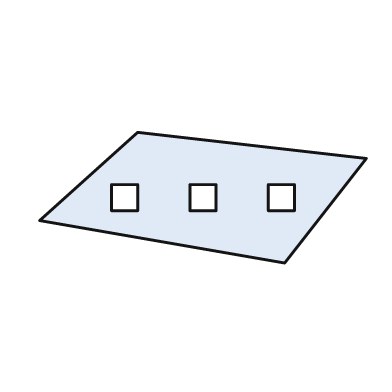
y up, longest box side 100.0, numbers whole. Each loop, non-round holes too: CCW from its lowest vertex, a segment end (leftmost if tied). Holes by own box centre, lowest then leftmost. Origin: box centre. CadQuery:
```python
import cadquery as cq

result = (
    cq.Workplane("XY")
    .moveTo(25.0, -20.0)
    .lineTo(50.0, 12.0)
    .lineTo(-20.0, 20.0)
    .lineTo(-50.0, -7.0)
    .close()
    .moveTo(-28.0, -4.0)
    .lineTo(-20.0, -4.0)
    .lineTo(-20.0, 4.0)
    .lineTo(-28.0, 4.0)
    .close()
    .moveTo(-4.0, -4.0)
    .lineTo(4.0, -4.0)
    .lineTo(4.0, 4.0)
    .lineTo(-4.0, 4.0)
    .close()
    .moveTo(20.0, -4.0)
    .lineTo(28.0, -4.0)
    .lineTo(28.0, 4.0)
    .lineTo(20.0, 4.0)
    .close()
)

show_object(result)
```